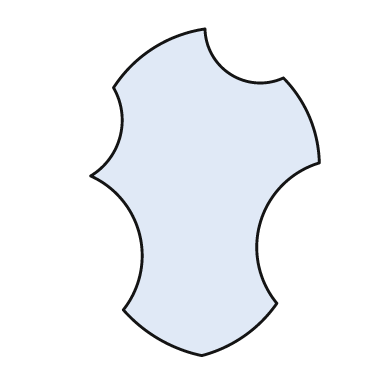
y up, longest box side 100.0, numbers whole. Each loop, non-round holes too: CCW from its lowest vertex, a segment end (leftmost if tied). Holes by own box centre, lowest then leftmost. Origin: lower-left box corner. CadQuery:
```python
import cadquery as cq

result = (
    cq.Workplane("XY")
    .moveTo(34.0, 0.0)
    .threePointArc((47.0, 6.0), (57.0, 16.0))
    .threePointArc((52.0, 41.0), (70.0, 59.0))
    .threePointArc((67.0, 73.0), (59.0, 85.0))
    .threePointArc((43.0, 86.0), (35.0, 100.0))
    .threePointArc((19.0, 94.0), (7.0, 82.0))
    .threePointArc((9.0, 67.0), (0.0, 55.0))
    .threePointArc((15.0, 37.0), (10.0, 14.0))
    .threePointArc((21.0, 5.0), (34.0, 0.0))
    .close()
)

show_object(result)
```